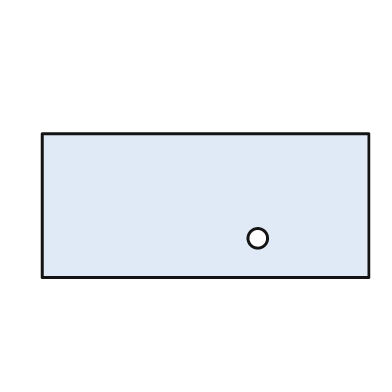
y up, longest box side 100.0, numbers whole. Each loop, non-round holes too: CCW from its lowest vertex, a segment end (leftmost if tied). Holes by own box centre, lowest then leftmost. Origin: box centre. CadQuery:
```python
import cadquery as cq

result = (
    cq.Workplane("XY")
    .moveTo(-50.0, -22.0)
    .lineTo(50.0, -22.0)
    .lineTo(50.0, 22.0)
    .lineTo(-50.0, 22.0)
    .close()
    .moveTo(16.0, -10.0)
    .circle(3.0)
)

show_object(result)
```